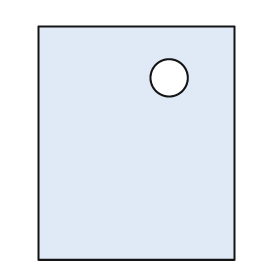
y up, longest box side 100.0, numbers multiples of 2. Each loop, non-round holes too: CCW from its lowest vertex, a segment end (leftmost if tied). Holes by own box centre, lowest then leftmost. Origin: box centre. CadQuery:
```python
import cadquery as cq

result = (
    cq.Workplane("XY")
    .moveTo(-42.0, -50.0)
    .lineTo(42.0, -50.0)
    .lineTo(42.0, 50.0)
    .lineTo(-42.0, 50.0)
    .close()
    .moveTo(14.0, 28.0)
    .circle(8.0)
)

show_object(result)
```